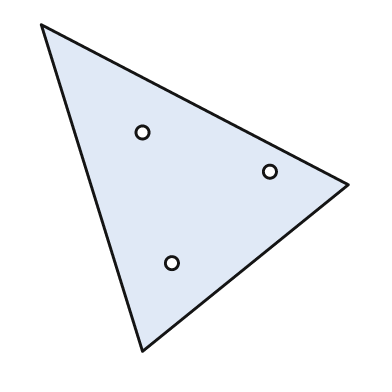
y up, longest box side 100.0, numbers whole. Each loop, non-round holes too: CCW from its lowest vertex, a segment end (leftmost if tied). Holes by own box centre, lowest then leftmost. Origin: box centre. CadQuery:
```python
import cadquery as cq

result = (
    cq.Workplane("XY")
    .moveTo(-16.0, -50.0)
    .lineTo(47.0, 1.0)
    .lineTo(-47.0, 50.0)
    .close()
    .moveTo(-7.0, -23.0)
    .circle(2.0)
    .moveTo(23.0, 5.0)
    .circle(2.0)
    .moveTo(-16.0, 17.0)
    .circle(2.0)
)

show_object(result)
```